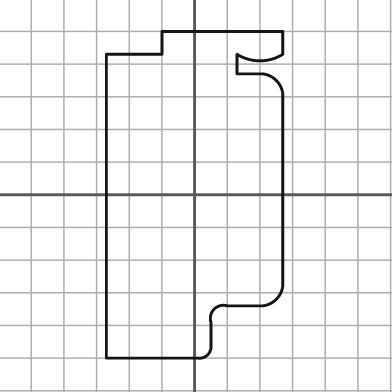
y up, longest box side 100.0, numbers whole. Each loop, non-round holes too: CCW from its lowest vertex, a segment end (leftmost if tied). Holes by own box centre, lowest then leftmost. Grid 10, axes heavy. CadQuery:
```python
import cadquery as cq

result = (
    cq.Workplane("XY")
    .moveTo(-27.0, -50.0)
    .lineTo(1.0, -50.0)
    .threePointArc((4.0, -49.0), (5.0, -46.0))
    .lineTo(5.0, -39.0)
    .threePointArc((6.0, -35.0), (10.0, -34.0))
    .lineTo(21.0, -34.0)
    .threePointArc((25.0, -32.0), (27.0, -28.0))
    .lineTo(27.0, 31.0)
    .threePointArc((25.0, 35.0), (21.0, 37.0))
    .lineTo(13.0, 37.0)
    .lineTo(13.0, 43.0)
    .threePointArc((20.0, 41.0), (27.0, 43.0))
    .lineTo(27.0, 50.0)
    .lineTo(-10.0, 50.0)
    .lineTo(-10.0, 43.0)
    .lineTo(-27.0, 43.0)
    .close()
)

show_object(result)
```